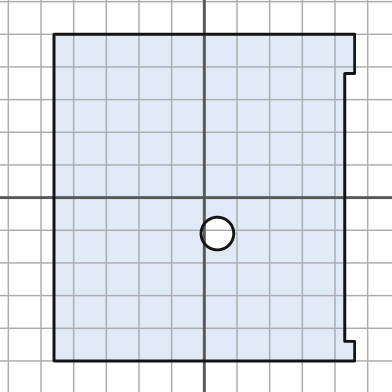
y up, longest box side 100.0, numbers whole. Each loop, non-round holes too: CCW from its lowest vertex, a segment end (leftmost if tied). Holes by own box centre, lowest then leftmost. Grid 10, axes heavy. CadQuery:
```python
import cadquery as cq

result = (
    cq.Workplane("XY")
    .moveTo(-46.0, -50.0)
    .lineTo(46.0, -50.0)
    .lineTo(46.0, -44.0)
    .lineTo(43.0, -44.0)
    .lineTo(43.0, 38.0)
    .lineTo(46.0, 38.0)
    .lineTo(46.0, 50.0)
    .lineTo(-46.0, 50.0)
    .close()
    .moveTo(4.0, -11.0)
    .circle(5.0)
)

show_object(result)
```